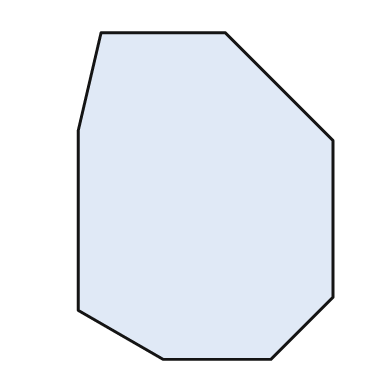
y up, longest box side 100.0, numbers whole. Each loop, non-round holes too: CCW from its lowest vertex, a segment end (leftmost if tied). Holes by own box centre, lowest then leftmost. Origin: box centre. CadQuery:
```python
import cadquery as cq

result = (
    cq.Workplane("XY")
    .moveTo(-13.0, -50.0)
    .lineTo(20.0, -50.0)
    .lineTo(39.0, -31.0)
    .lineTo(39.0, 17.0)
    .lineTo(6.0, 50.0)
    .lineTo(-32.0, 50.0)
    .lineTo(-39.0, 20.0)
    .lineTo(-39.0, -35.0)
    .close()
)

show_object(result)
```